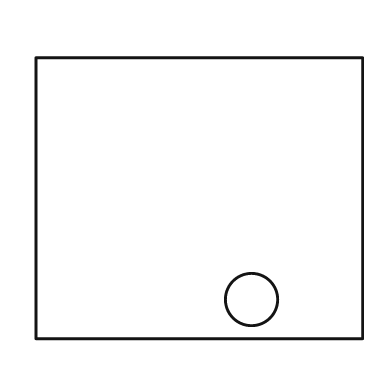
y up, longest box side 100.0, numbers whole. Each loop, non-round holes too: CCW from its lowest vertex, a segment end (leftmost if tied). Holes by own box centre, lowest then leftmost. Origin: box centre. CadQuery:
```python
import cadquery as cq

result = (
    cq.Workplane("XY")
    .moveTo(-50.0, -43.0)
    .lineTo(50.0, -43.0)
    .lineTo(50.0, 43.0)
    .lineTo(-50.0, 43.0)
    .close()
    .moveTo(16.0, -31.0)
    .circle(8.0)
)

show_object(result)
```